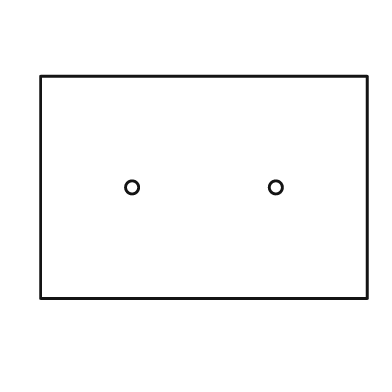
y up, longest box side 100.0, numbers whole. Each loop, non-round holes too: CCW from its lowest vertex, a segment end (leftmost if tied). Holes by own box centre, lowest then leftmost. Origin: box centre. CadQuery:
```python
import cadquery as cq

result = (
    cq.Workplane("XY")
    .moveTo(-50.0, -34.0)
    .lineTo(50.0, -34.0)
    .lineTo(50.0, 34.0)
    .lineTo(-50.0, 34.0)
    .close()
    .moveTo(-22.0, 0.0)
    .circle(2.0)
    .moveTo(22.0, 0.0)
    .circle(2.0)
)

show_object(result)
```